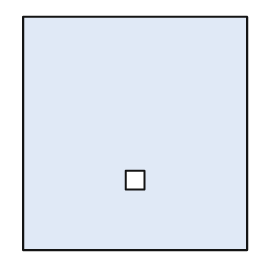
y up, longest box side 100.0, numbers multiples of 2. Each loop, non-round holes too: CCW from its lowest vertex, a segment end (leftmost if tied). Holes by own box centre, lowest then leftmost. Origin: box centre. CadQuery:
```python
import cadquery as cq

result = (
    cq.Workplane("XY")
    .moveTo(-48.0, -50.0)
    .lineTo(48.0, -50.0)
    .lineTo(48.0, 50.0)
    .lineTo(-48.0, 50.0)
    .close()
    .moveTo(-4.0, -24.0)
    .lineTo(4.0, -24.0)
    .lineTo(4.0, -16.0)
    .lineTo(-4.0, -16.0)
    .close()
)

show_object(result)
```